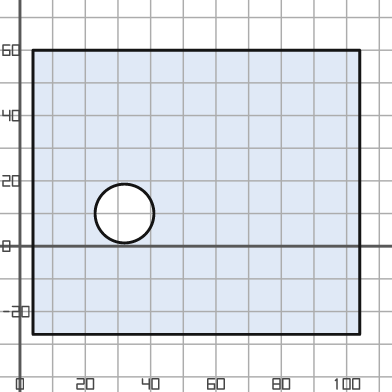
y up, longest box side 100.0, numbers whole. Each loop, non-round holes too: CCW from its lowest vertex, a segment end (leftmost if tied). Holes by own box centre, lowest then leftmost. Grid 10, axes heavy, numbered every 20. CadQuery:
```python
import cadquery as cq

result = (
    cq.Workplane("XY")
    .moveTo(4.0, -27.0)
    .lineTo(104.0, -27.0)
    .lineTo(104.0, 60.0)
    .lineTo(4.0, 60.0)
    .close()
    .moveTo(32.0, 10.0)
    .circle(9.0)
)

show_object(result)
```